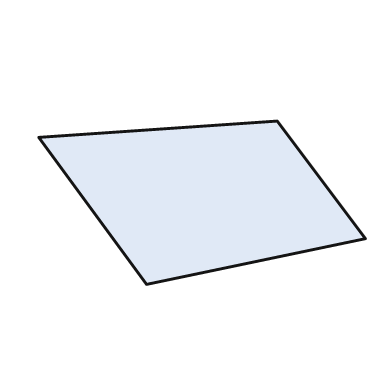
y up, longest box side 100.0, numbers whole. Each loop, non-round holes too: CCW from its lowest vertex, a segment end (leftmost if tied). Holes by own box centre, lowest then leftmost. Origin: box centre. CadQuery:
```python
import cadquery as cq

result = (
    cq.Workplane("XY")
    .moveTo(-17.0, -25.0)
    .lineTo(50.0, -11.0)
    .lineTo(23.0, 25.0)
    .lineTo(-50.0, 20.0)
    .close()
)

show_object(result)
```